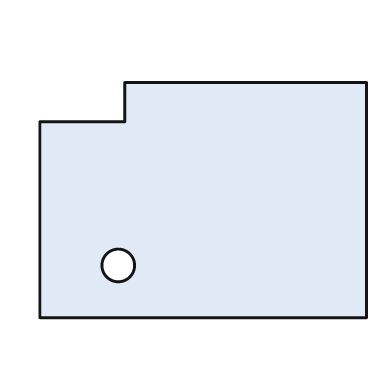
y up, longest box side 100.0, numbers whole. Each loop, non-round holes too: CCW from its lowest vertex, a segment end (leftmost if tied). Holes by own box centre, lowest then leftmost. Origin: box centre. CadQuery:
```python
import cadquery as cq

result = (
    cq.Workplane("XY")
    .moveTo(-50.0, -36.0)
    .lineTo(50.0, -36.0)
    .lineTo(50.0, 36.0)
    .lineTo(-24.0, 36.0)
    .lineTo(-24.0, 24.0)
    .lineTo(-50.0, 24.0)
    .close()
    .moveTo(-26.0, -20.0)
    .circle(5.0)
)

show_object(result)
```